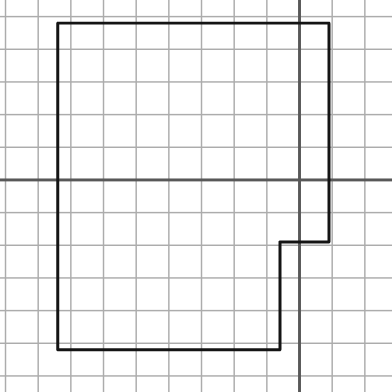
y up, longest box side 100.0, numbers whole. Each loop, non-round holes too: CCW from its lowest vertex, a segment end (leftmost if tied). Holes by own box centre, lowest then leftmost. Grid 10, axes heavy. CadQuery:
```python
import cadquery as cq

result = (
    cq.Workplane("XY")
    .moveTo(-74.0, -52.0)
    .lineTo(-6.0, -52.0)
    .lineTo(-6.0, -19.0)
    .lineTo(9.0, -19.0)
    .lineTo(9.0, 48.0)
    .lineTo(-74.0, 48.0)
    .close()
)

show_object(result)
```